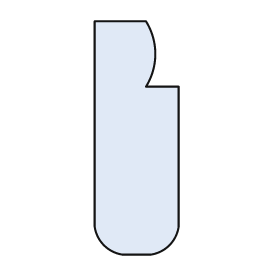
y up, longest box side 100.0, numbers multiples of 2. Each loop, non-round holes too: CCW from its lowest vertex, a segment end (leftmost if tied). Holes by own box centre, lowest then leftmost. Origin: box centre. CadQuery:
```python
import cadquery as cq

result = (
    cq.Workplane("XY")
    .moveTo(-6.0, -50.0)
    .lineTo(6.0, -50.0)
    .threePointArc((14.0, -46.0), (18.0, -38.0))
    .lineTo(18.0, 22.0)
    .lineTo(4.0, 22.0)
    .threePointArc((8.0, 36.0), (4.0, 50.0))
    .lineTo(-18.0, 50.0)
    .lineTo(-18.0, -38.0)
    .threePointArc((-14.0, -46.0), (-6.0, -50.0))
    .close()
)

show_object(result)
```